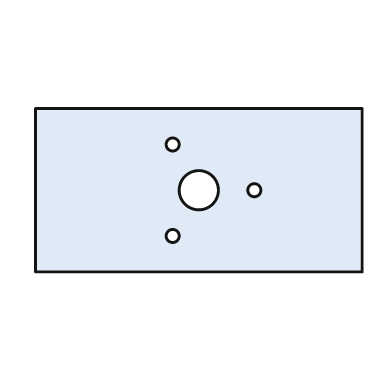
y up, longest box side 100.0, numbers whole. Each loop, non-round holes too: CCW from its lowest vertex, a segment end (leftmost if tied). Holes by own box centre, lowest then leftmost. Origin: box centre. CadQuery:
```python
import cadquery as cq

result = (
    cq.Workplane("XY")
    .moveTo(-50.0, -25.0)
    .lineTo(50.0, -25.0)
    .lineTo(50.0, 25.0)
    .lineTo(-50.0, 25.0)
    .close()
    .moveTo(-8.0, -14.0)
    .circle(2.0)
    .moveTo(0.0, 0.0)
    .circle(6.0)
    .moveTo(17.0, 0.0)
    .circle(2.0)
    .moveTo(-8.0, 14.0)
    .circle(2.0)
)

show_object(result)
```